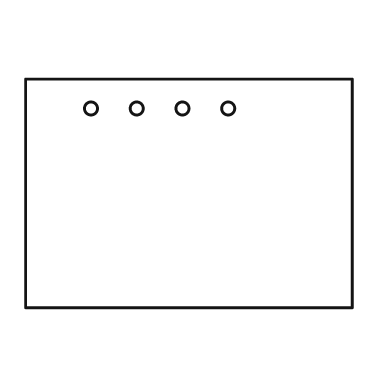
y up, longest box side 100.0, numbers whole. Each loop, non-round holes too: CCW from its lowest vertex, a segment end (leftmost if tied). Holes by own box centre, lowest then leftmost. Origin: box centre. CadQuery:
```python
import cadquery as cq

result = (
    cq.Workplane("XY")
    .moveTo(-50.0, -35.0)
    .lineTo(50.0, -35.0)
    .lineTo(50.0, 35.0)
    .lineTo(-50.0, 35.0)
    .close()
    .moveTo(-30.0, 26.0)
    .circle(2.0)
    .moveTo(-16.0, 26.0)
    .circle(2.0)
    .moveTo(-2.0, 26.0)
    .circle(2.0)
    .moveTo(12.0, 26.0)
    .circle(2.0)
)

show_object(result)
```